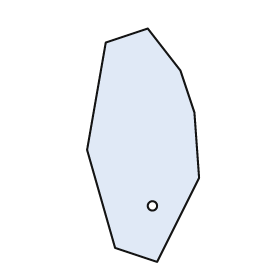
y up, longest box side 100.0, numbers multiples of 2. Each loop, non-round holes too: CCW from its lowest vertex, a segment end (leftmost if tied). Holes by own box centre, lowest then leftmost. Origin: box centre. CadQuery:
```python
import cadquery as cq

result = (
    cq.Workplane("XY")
    .moveTo(6.0, -50.0)
    .lineTo(24.0, -14.0)
    .lineTo(22.0, 14.0)
    .lineTo(16.0, 32.0)
    .lineTo(2.0, 50.0)
    .lineTo(-16.0, 44.0)
    .lineTo(-24.0, -2.0)
    .lineTo(-12.0, -44.0)
    .close()
    .moveTo(4.0, -26.0)
    .circle(2.0)
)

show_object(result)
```